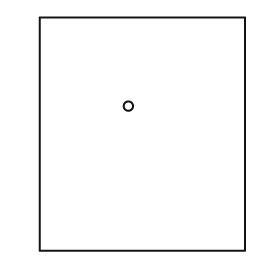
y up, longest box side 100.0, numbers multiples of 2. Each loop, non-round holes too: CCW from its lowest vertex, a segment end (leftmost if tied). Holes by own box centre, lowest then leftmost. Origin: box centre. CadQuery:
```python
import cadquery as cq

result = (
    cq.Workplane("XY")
    .moveTo(-44.0, -50.0)
    .lineTo(44.0, -50.0)
    .lineTo(44.0, 50.0)
    .lineTo(-44.0, 50.0)
    .close()
    .moveTo(-6.0, 12.0)
    .circle(2.0)
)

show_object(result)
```